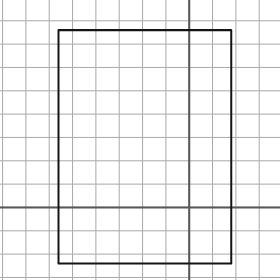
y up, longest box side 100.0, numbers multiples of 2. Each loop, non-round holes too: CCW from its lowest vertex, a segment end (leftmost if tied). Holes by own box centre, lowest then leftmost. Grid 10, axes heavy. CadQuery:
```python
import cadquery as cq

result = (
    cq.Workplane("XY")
    .moveTo(-56.0, -24.0)
    .lineTo(18.0, -24.0)
    .lineTo(18.0, 76.0)
    .lineTo(-56.0, 76.0)
    .close()
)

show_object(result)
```